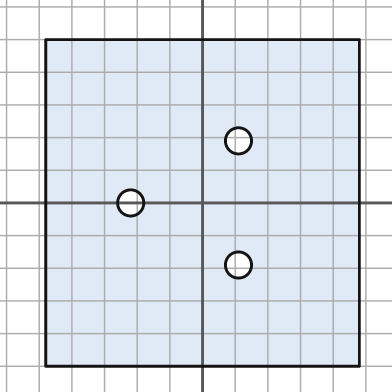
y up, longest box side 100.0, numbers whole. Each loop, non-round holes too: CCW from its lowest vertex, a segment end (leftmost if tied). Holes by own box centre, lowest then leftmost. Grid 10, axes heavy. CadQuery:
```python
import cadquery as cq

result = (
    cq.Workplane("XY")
    .moveTo(-48.0, -50.0)
    .lineTo(48.0, -50.0)
    .lineTo(48.0, 50.0)
    .lineTo(-48.0, 50.0)
    .close()
    .moveTo(11.0, -19.0)
    .circle(4.0)
    .moveTo(-22.0, 0.0)
    .circle(4.0)
    .moveTo(11.0, 19.0)
    .circle(4.0)
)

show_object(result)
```